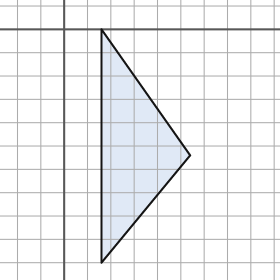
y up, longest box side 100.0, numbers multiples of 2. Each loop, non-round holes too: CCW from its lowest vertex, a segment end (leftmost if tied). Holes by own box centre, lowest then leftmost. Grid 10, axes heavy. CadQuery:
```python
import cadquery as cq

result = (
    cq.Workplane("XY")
    .moveTo(16.0, -100.0)
    .lineTo(54.0, -54.0)
    .lineTo(16.0, 0.0)
    .close()
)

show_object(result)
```